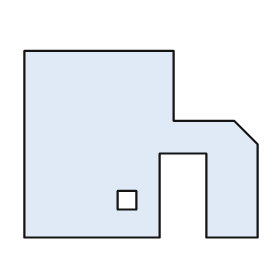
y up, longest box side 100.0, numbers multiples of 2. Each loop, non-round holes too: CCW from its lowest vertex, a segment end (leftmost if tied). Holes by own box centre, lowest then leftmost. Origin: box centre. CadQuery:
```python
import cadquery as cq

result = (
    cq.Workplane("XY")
    .moveTo(-50.0, -40.0)
    .lineTo(8.0, -40.0)
    .lineTo(8.0, -4.0)
    .lineTo(28.0, -4.0)
    .lineTo(28.0, -40.0)
    .lineTo(50.0, -40.0)
    .lineTo(50.0, 0.0)
    .lineTo(40.0, 10.0)
    .lineTo(14.0, 10.0)
    .lineTo(14.0, 40.0)
    .lineTo(-50.0, 40.0)
    .close()
    .moveTo(-10.0, -28.0)
    .lineTo(-2.0, -28.0)
    .lineTo(-2.0, -20.0)
    .lineTo(-10.0, -20.0)
    .close()
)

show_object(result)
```